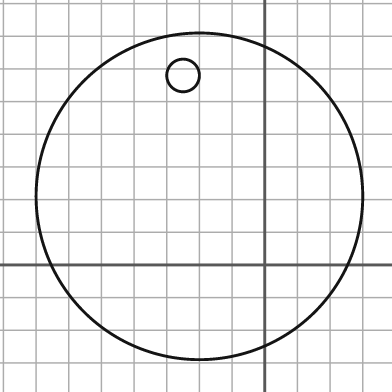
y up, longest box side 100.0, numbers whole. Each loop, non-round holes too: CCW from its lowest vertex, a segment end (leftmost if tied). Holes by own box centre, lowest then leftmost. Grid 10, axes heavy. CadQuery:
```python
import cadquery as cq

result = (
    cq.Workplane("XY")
    .moveTo(-20.0, 21.0)
    .circle(50.0)
    .moveTo(-25.0, 58.0)
    .circle(5.0)
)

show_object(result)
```